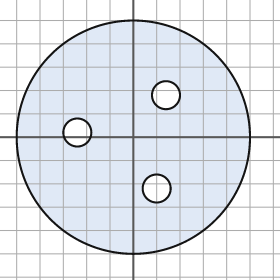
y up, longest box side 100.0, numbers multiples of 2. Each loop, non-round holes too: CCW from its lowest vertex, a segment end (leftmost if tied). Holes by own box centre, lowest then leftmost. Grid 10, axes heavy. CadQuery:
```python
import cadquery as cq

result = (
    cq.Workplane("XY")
    .moveTo(0.0, 0.0)
    .circle(50.0)
    .moveTo(10.0, -22.0)
    .circle(6.0)
    .moveTo(-24.0, 2.0)
    .circle(6.0)
    .moveTo(14.0, 18.0)
    .circle(6.0)
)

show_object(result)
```